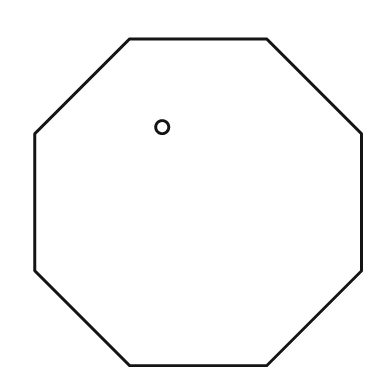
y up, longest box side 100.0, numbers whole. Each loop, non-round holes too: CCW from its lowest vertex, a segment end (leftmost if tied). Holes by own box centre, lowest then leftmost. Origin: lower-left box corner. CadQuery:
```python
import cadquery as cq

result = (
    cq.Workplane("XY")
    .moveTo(29.0, 0.0)
    .lineTo(71.0, 0.0)
    .lineTo(100.0, 29.0)
    .lineTo(100.0, 71.0)
    .lineTo(71.0, 100.0)
    .lineTo(29.0, 100.0)
    .lineTo(0.0, 71.0)
    .lineTo(0.0, 29.0)
    .close()
    .moveTo(39.0, 73.0)
    .circle(2.0)
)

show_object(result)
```